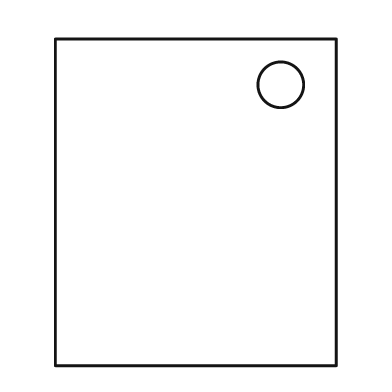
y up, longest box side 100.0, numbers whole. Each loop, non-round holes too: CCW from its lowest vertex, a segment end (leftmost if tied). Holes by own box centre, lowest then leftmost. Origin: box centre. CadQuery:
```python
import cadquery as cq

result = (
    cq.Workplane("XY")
    .moveTo(-43.0, -50.0)
    .lineTo(43.0, -50.0)
    .lineTo(43.0, 50.0)
    .lineTo(-43.0, 50.0)
    .close()
    .moveTo(26.0, 36.0)
    .circle(7.0)
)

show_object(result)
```